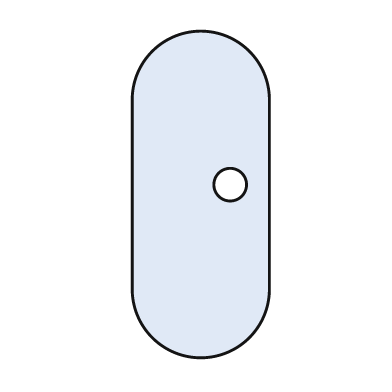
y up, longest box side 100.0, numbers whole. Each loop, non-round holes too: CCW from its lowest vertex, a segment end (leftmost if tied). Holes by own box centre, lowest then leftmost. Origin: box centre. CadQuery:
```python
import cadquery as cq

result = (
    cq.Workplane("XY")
    .moveTo(-21.0, -29.0)
    .threePointArc((0.0, -50.0), (21.0, -29.0))
    .lineTo(21.0, 29.0)
    .threePointArc((0.0, 50.0), (-21.0, 29.0))
    .close()
    .moveTo(9.0, 3.0)
    .circle(5.0)
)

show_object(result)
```